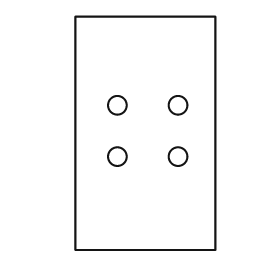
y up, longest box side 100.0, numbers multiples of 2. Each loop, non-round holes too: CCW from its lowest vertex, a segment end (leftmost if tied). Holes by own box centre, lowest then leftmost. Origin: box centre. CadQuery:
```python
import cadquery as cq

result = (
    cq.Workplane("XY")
    .moveTo(-30.0, -50.0)
    .lineTo(30.0, -50.0)
    .lineTo(30.0, 50.0)
    .lineTo(-30.0, 50.0)
    .close()
    .moveTo(-12.0, -10.0)
    .circle(4.0)
    .moveTo(14.0, -10.0)
    .circle(4.0)
    .moveTo(-12.0, 12.0)
    .circle(4.0)
    .moveTo(14.0, 12.0)
    .circle(4.0)
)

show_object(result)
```